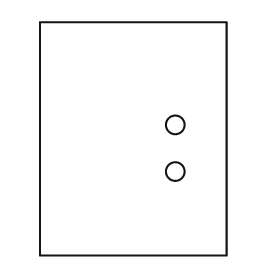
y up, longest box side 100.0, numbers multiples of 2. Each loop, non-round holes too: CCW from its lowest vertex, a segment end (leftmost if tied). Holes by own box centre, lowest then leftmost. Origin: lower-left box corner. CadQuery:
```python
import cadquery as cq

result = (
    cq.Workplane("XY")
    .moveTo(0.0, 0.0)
    .lineTo(80.0, 0.0)
    .lineTo(80.0, 100.0)
    .lineTo(0.0, 100.0)
    .close()
    .moveTo(58.0, 36.0)
    .circle(4.0)
    .moveTo(58.0, 56.0)
    .circle(4.0)
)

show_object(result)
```